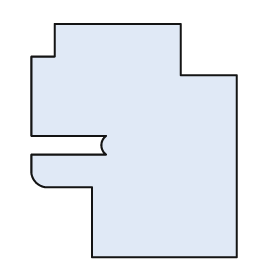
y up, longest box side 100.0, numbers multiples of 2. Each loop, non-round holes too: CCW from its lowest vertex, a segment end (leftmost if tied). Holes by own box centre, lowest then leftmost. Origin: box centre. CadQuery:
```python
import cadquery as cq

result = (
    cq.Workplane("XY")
    .moveTo(-18.0, -50.0)
    .lineTo(44.0, -50.0)
    .lineTo(44.0, 28.0)
    .lineTo(20.0, 28.0)
    .lineTo(20.0, 50.0)
    .lineTo(-34.0, 50.0)
    .lineTo(-34.0, 36.0)
    .lineTo(-44.0, 36.0)
    .lineTo(-44.0, 2.0)
    .lineTo(-12.0, 2.0)
    .threePointArc((-14.0, -2.0), (-12.0, -6.0))
    .lineTo(-44.0, -6.0)
    .lineTo(-44.0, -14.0)
    .threePointArc((-42.0, -18.0), (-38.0, -20.0))
    .lineTo(-18.0, -20.0)
    .close()
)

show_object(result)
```